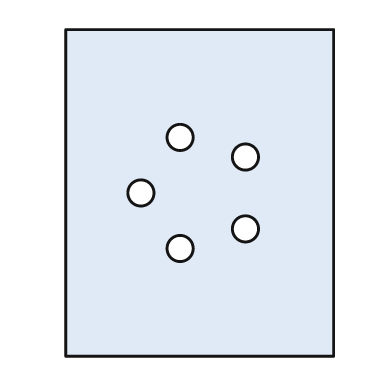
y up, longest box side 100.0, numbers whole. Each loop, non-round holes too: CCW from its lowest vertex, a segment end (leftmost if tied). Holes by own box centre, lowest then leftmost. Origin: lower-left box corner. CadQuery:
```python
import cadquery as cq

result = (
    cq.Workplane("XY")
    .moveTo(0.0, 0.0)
    .lineTo(82.0, 0.0)
    .lineTo(82.0, 100.0)
    .lineTo(0.0, 100.0)
    .close()
    .moveTo(35.0, 33.0)
    .circle(4.0)
    .moveTo(55.0, 39.0)
    .circle(4.0)
    .moveTo(23.0, 50.0)
    .circle(4.0)
    .moveTo(55.0, 61.0)
    .circle(4.0)
    .moveTo(35.0, 67.0)
    .circle(4.0)
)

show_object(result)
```